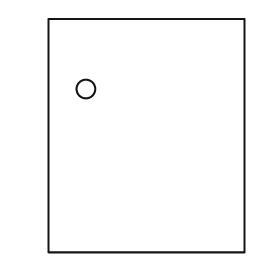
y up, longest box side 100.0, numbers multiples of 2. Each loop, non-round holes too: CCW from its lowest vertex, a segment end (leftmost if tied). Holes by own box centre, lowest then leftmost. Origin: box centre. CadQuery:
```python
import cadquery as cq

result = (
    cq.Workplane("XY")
    .moveTo(-42.0, -50.0)
    .lineTo(42.0, -50.0)
    .lineTo(42.0, 50.0)
    .lineTo(-42.0, 50.0)
    .close()
    .moveTo(-26.0, 20.0)
    .circle(4.0)
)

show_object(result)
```